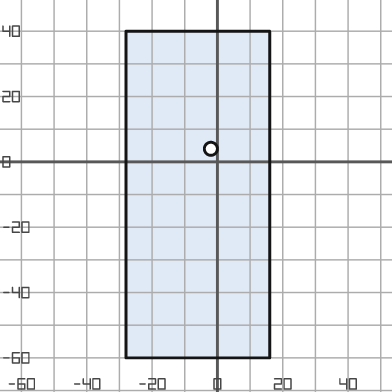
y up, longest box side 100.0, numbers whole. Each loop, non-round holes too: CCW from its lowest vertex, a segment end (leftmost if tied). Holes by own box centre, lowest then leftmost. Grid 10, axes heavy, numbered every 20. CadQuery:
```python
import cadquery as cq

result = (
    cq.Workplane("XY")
    .moveTo(-28.0, -60.0)
    .lineTo(16.0, -60.0)
    .lineTo(16.0, 40.0)
    .lineTo(-28.0, 40.0)
    .close()
    .moveTo(-2.0, 4.0)
    .circle(2.0)
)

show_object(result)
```